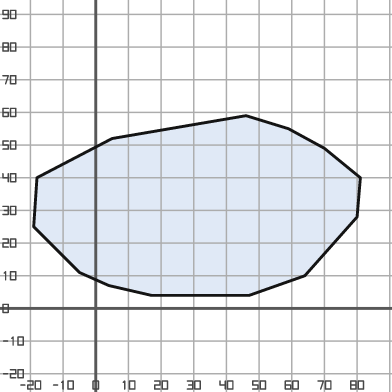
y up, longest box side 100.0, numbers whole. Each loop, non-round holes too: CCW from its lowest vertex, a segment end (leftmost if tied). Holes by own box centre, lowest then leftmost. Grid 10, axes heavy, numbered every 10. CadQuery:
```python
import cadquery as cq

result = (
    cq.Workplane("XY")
    .moveTo(17.0, 4.0)
    .lineTo(47.0, 4.0)
    .lineTo(64.0, 10.0)
    .lineTo(80.0, 28.0)
    .lineTo(81.0, 40.0)
    .lineTo(70.0, 49.0)
    .lineTo(59.0, 55.0)
    .lineTo(46.0, 59.0)
    .lineTo(5.0, 52.0)
    .lineTo(-18.0, 40.0)
    .lineTo(-19.0, 25.0)
    .lineTo(-5.0, 11.0)
    .lineTo(4.0, 7.0)
    .close()
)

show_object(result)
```